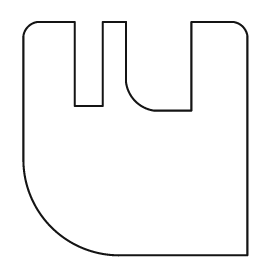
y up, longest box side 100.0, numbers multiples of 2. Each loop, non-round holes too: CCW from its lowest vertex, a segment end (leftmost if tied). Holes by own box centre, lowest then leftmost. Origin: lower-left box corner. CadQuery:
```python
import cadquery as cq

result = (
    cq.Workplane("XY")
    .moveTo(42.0, 0.0)
    .lineTo(96.0, 0.0)
    .lineTo(96.0, 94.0)
    .threePointArc((94.0, 98.0), (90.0, 100.0))
    .lineTo(72.0, 100.0)
    .lineTo(72.0, 62.0)
    .lineTo(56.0, 62.0)
    .threePointArc((48.0, 66.0), (44.0, 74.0))
    .lineTo(44.0, 100.0)
    .lineTo(34.0, 100.0)
    .lineTo(34.0, 64.0)
    .lineTo(22.0, 64.0)
    .lineTo(22.0, 100.0)
    .lineTo(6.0, 100.0)
    .threePointArc((2.0, 98.0), (0.0, 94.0))
    .lineTo(0.0, 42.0)
    .threePointArc((12.0, 12.0), (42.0, 0.0))
    .close()
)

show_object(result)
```